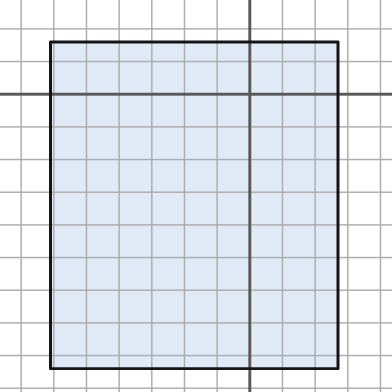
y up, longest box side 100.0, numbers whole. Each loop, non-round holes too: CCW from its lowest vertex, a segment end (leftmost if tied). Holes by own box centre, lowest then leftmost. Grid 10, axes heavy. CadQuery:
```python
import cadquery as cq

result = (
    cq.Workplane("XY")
    .moveTo(-61.0, -84.0)
    .lineTo(27.0, -84.0)
    .lineTo(27.0, 16.0)
    .lineTo(-61.0, 16.0)
    .close()
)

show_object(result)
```